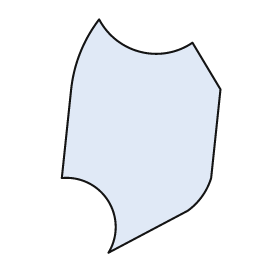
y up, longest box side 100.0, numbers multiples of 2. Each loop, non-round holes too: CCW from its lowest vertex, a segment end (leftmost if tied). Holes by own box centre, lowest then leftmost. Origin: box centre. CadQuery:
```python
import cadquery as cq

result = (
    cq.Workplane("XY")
    .moveTo(-14.0, -50.0)
    .lineTo(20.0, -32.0)
    .threePointArc((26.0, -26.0), (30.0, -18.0))
    .lineTo(34.0, 20.0)
    .lineTo(22.0, 40.0)
    .threePointArc((0.0, 36.0), (-18.0, 50.0))
    .threePointArc((-26.0, 36.0), (-30.0, 20.0))
    .lineTo(-34.0, -18.0)
    .threePointArc((-14.0, -28.0), (-14.0, -50.0))
    .close()
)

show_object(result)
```